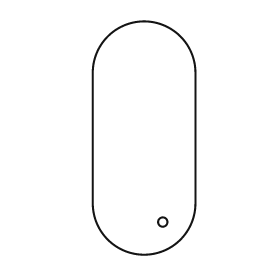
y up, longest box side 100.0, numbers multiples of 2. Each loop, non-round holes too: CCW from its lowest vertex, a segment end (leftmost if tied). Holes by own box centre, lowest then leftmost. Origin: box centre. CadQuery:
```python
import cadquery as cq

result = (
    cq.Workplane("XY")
    .moveTo(-22.0, -28.0)
    .threePointArc((0.0, -50.0), (22.0, -28.0))
    .lineTo(22.0, 28.0)
    .threePointArc((0.0, 50.0), (-22.0, 28.0))
    .close()
    .moveTo(8.0, -36.0)
    .circle(2.0)
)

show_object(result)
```